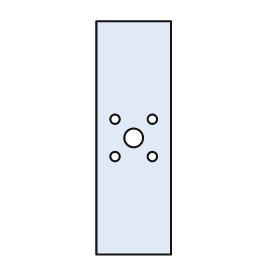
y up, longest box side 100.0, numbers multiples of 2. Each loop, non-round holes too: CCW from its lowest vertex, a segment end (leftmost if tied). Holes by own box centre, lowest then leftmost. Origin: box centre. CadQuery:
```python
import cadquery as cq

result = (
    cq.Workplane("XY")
    .moveTo(-16.0, -50.0)
    .lineTo(16.0, -50.0)
    .lineTo(16.0, 50.0)
    .lineTo(-16.0, 50.0)
    .close()
    .moveTo(-8.0, -8.0)
    .circle(2.0)
    .moveTo(8.0, -8.0)
    .circle(2.0)
    .moveTo(0.0, 0.0)
    .circle(4.0)
    .moveTo(-8.0, 8.0)
    .circle(2.0)
    .moveTo(8.0, 8.0)
    .circle(2.0)
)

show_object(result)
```